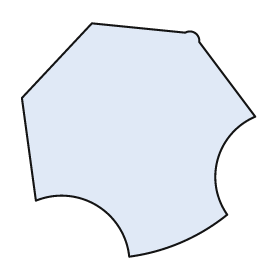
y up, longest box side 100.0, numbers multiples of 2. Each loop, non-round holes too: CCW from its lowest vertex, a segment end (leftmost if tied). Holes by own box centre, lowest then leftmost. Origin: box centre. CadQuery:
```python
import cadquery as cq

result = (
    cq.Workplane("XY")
    .moveTo(-4.0, -50.0)
    .threePointArc((18.0, -44.0), (38.0, -32.0))
    .threePointArc((34.0, -8.0), (50.0, 10.0))
    .lineTo(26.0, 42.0)
    .threePointArc((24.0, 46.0), (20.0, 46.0))
    .lineTo(-20.0, 50.0)
    .lineTo(-50.0, 18.0)
    .lineTo(-44.0, -26.0)
    .threePointArc((-18.0, -28.0), (-4.0, -50.0))
    .close()
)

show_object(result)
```